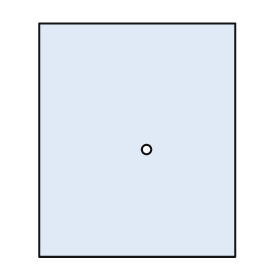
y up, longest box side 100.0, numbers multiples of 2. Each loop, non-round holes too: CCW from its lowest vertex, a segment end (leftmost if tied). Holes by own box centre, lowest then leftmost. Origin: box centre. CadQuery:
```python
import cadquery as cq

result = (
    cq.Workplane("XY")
    .moveTo(-42.0, -50.0)
    .lineTo(42.0, -50.0)
    .lineTo(42.0, 50.0)
    .lineTo(-42.0, 50.0)
    .close()
    .moveTo(4.0, -4.0)
    .circle(2.0)
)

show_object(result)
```